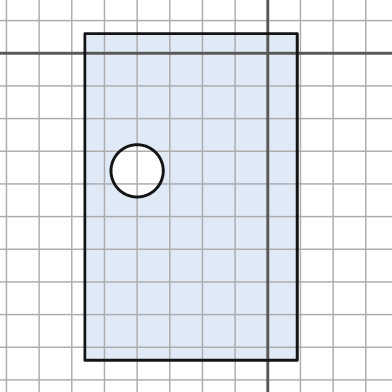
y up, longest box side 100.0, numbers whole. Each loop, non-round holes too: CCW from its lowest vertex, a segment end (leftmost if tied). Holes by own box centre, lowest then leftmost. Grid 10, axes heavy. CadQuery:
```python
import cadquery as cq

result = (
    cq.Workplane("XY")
    .moveTo(-56.0, -94.0)
    .lineTo(9.0, -94.0)
    .lineTo(9.0, 6.0)
    .lineTo(-56.0, 6.0)
    .close()
    .moveTo(-40.0, -36.0)
    .circle(8.0)
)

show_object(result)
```